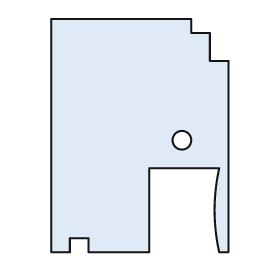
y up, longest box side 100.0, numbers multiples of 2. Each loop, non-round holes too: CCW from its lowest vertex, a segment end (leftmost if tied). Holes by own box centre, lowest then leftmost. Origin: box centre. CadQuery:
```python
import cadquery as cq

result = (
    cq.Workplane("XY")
    .moveTo(-38.0, -50.0)
    .lineTo(-30.0, -50.0)
    .lineTo(-30.0, -44.0)
    .lineTo(-22.0, -44.0)
    .lineTo(-22.0, -50.0)
    .lineTo(4.0, -50.0)
    .lineTo(4.0, -14.0)
    .lineTo(34.0, -14.0)
    .threePointArc((32.0, -32.0), (34.0, -50.0))
    .lineTo(38.0, -50.0)
    .lineTo(38.0, 32.0)
    .lineTo(30.0, 32.0)
    .lineTo(30.0, 44.0)
    .lineTo(22.0, 44.0)
    .lineTo(22.0, 50.0)
    .lineTo(-38.0, 50.0)
    .close()
    .moveTo(18.0, -2.0)
    .circle(4.0)
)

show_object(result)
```